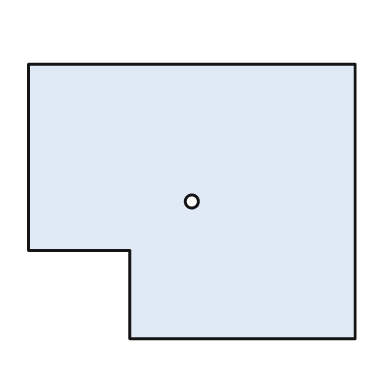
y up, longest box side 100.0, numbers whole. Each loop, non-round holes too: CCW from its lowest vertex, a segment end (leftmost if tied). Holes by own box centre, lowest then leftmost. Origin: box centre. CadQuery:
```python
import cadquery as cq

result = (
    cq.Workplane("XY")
    .moveTo(-19.0, -42.0)
    .lineTo(50.0, -42.0)
    .lineTo(50.0, 42.0)
    .lineTo(-50.0, 42.0)
    .lineTo(-50.0, -15.0)
    .lineTo(-19.0, -15.0)
    .close()
    .moveTo(0.0, 0.0)
    .circle(2.0)
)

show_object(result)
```